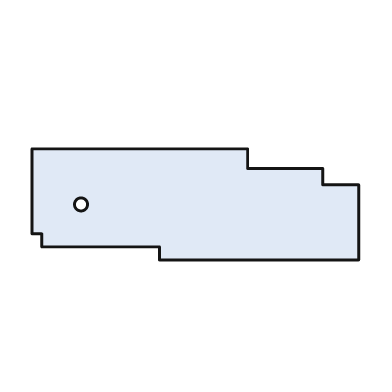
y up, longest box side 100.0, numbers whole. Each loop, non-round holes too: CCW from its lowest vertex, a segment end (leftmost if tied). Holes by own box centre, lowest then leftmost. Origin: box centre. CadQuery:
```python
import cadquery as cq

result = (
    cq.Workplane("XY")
    .moveTo(-11.0, -17.0)
    .lineTo(50.0, -17.0)
    .lineTo(50.0, 6.0)
    .lineTo(39.0, 6.0)
    .lineTo(39.0, 11.0)
    .lineTo(16.0, 11.0)
    .lineTo(16.0, 17.0)
    .lineTo(-50.0, 17.0)
    .lineTo(-50.0, -9.0)
    .lineTo(-47.0, -9.0)
    .lineTo(-47.0, -13.0)
    .lineTo(-11.0, -13.0)
    .close()
    .moveTo(-35.0, 0.0)
    .circle(2.0)
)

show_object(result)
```